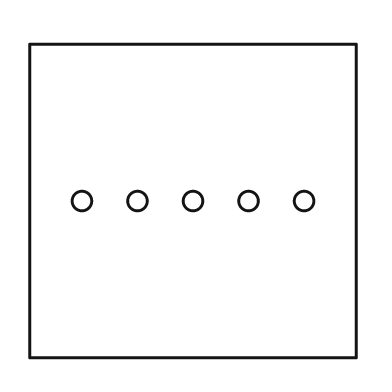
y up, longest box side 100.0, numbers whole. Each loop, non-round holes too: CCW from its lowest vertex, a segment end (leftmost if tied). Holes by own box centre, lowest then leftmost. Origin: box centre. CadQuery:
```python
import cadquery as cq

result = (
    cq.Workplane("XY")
    .moveTo(-50.0, -48.0)
    .lineTo(50.0, -48.0)
    .lineTo(50.0, 48.0)
    .lineTo(-50.0, 48.0)
    .close()
    .moveTo(-34.0, 0.0)
    .circle(3.0)
    .moveTo(-17.0, 0.0)
    .circle(3.0)
    .moveTo(0.0, 0.0)
    .circle(3.0)
    .moveTo(17.0, 0.0)
    .circle(3.0)
    .moveTo(34.0, 0.0)
    .circle(3.0)
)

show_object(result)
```